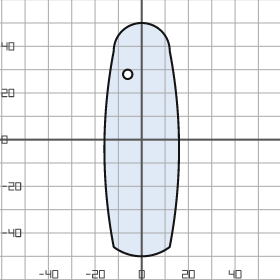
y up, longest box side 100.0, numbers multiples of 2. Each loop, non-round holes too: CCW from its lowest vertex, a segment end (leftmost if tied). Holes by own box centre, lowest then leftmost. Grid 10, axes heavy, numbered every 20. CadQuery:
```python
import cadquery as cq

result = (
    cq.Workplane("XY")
    .moveTo(-12.0, -46.0)
    .threePointArc((0.0, -50.0), (12.0, -46.0))
    .threePointArc((16.0, -4.0), (12.0, 38.0))
    .threePointArc((0.0, 50.0), (-12.0, 38.0))
    .threePointArc((-16.0, -4.0), (-12.0, -46.0))
    .close()
    .moveTo(-6.0, 28.0)
    .circle(2.0)
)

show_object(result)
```